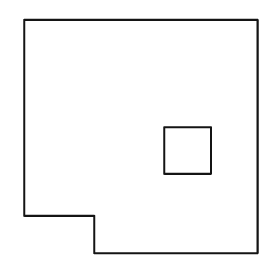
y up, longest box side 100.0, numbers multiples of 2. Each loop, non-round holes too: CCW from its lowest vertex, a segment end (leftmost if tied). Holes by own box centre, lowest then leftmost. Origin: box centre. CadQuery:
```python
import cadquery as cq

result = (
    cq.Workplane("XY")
    .moveTo(-20.0, -50.0)
    .lineTo(50.0, -50.0)
    .lineTo(50.0, 50.0)
    .lineTo(-50.0, 50.0)
    .lineTo(-50.0, -34.0)
    .lineTo(-20.0, -34.0)
    .close()
    .moveTo(10.0, -16.0)
    .lineTo(30.0, -16.0)
    .lineTo(30.0, 4.0)
    .lineTo(10.0, 4.0)
    .close()
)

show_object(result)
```